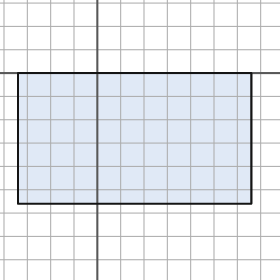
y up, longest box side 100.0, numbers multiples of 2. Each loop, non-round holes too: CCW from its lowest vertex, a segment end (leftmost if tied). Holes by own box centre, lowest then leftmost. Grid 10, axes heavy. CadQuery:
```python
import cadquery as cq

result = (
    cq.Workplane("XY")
    .moveTo(-34.0, -56.0)
    .lineTo(66.0, -56.0)
    .lineTo(66.0, 0.0)
    .lineTo(-34.0, 0.0)
    .close()
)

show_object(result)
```